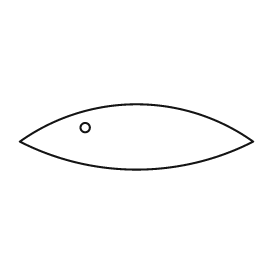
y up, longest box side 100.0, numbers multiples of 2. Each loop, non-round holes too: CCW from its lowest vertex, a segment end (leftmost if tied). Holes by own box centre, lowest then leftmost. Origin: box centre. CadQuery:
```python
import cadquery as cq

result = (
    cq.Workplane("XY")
    .moveTo(-50.0, -2.0)
    .threePointArc((0.0, -14.0), (50.0, -2.0))
    .threePointArc((0.0, 14.0), (-50.0, -2.0))
    .close()
    .moveTo(-22.0, 4.0)
    .circle(2.0)
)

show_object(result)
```